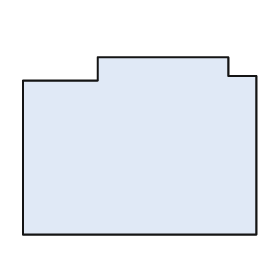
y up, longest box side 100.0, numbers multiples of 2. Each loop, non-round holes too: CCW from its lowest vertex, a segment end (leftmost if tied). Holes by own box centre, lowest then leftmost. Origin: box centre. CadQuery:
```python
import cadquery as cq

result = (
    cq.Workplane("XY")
    .moveTo(-50.0, -38.0)
    .lineTo(50.0, -38.0)
    .lineTo(50.0, 30.0)
    .lineTo(38.0, 30.0)
    .lineTo(38.0, 38.0)
    .lineTo(-18.0, 38.0)
    .lineTo(-18.0, 28.0)
    .lineTo(-50.0, 28.0)
    .close()
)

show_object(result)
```